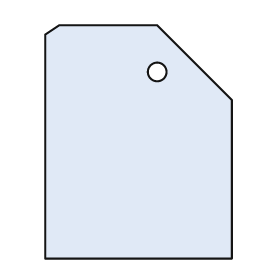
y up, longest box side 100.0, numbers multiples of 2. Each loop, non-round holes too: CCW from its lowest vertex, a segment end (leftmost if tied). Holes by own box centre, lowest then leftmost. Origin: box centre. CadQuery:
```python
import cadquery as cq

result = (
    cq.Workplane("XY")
    .moveTo(-40.0, -50.0)
    .lineTo(40.0, -50.0)
    .lineTo(40.0, 18.0)
    .lineTo(8.0, 50.0)
    .lineTo(-34.0, 50.0)
    .lineTo(-40.0, 46.0)
    .close()
    .moveTo(8.0, 30.0)
    .circle(4.0)
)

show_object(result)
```